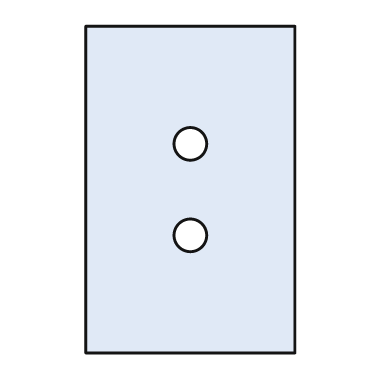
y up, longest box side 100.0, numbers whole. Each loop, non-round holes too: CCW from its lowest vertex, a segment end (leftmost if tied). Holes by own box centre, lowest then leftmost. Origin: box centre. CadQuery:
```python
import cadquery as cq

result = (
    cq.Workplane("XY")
    .moveTo(-32.0, -50.0)
    .lineTo(32.0, -50.0)
    .lineTo(32.0, 50.0)
    .lineTo(-32.0, 50.0)
    .close()
    .moveTo(0.0, -14.0)
    .circle(5.0)
    .moveTo(0.0, 14.0)
    .circle(5.0)
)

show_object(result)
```